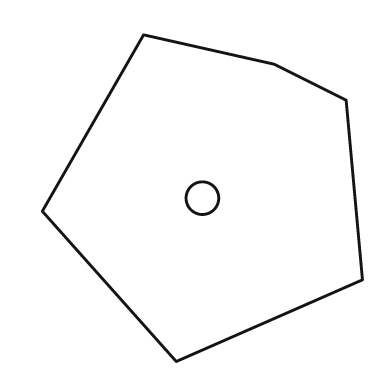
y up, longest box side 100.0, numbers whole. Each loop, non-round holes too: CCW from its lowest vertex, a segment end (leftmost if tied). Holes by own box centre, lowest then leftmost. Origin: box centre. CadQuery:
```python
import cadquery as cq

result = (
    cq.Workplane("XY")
    .moveTo(-8.0, -50.0)
    .lineTo(49.0, -25.0)
    .lineTo(44.0, 30.0)
    .lineTo(22.0, 41.0)
    .lineTo(-18.0, 50.0)
    .lineTo(-49.0, -4.0)
    .close()
    .moveTo(0.0, 0.0)
    .circle(5.0)
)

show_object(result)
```